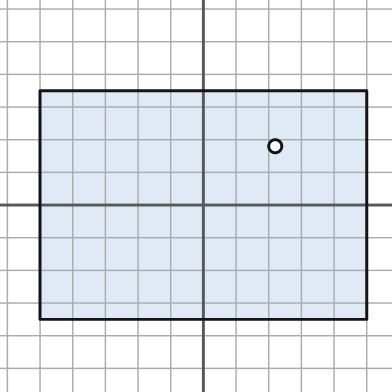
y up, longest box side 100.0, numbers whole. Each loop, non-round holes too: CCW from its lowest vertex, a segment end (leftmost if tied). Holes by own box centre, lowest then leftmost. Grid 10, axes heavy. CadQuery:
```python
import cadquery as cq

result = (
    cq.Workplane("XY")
    .moveTo(-50.0, -35.0)
    .lineTo(50.0, -35.0)
    .lineTo(50.0, 35.0)
    .lineTo(-50.0, 35.0)
    .close()
    .moveTo(22.0, 18.0)
    .circle(2.0)
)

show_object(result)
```